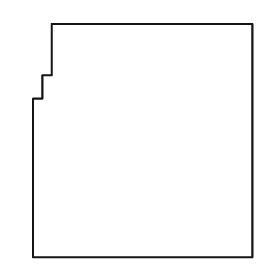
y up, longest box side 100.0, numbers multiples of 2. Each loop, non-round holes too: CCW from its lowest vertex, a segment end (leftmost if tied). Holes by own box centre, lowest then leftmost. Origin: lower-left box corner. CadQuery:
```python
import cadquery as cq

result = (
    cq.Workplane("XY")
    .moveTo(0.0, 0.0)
    .lineTo(94.0, 0.0)
    .lineTo(94.0, 100.0)
    .lineTo(8.0, 100.0)
    .lineTo(8.0, 78.0)
    .lineTo(4.0, 78.0)
    .lineTo(4.0, 68.0)
    .lineTo(0.0, 68.0)
    .close()
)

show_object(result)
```